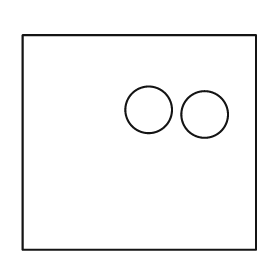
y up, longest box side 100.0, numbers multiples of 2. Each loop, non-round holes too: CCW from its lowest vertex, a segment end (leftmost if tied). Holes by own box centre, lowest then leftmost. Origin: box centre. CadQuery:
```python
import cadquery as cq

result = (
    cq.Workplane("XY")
    .moveTo(-50.0, -46.0)
    .lineTo(50.0, -46.0)
    .lineTo(50.0, 46.0)
    .lineTo(-50.0, 46.0)
    .close()
    .moveTo(28.0, 12.0)
    .circle(10.0)
    .moveTo(4.0, 14.0)
    .circle(10.0)
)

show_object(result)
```